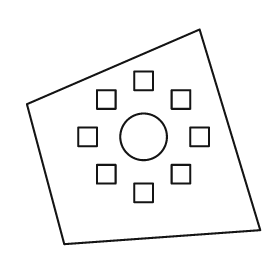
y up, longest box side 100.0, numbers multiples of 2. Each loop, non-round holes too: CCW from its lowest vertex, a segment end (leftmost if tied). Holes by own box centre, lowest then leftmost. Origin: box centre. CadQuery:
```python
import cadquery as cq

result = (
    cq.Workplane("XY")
    .moveTo(-34.0, -46.0)
    .lineTo(50.0, -40.0)
    .lineTo(24.0, 46.0)
    .lineTo(-50.0, 14.0)
    .close()
    .moveTo(-4.0, -28.0)
    .lineTo(4.0, -28.0)
    .lineTo(4.0, -20.0)
    .lineTo(-4.0, -20.0)
    .close()
    .moveTo(-20.0, -20.0)
    .lineTo(-12.0, -20.0)
    .lineTo(-12.0, -12.0)
    .lineTo(-20.0, -12.0)
    .close()
    .moveTo(12.0, -20.0)
    .lineTo(20.0, -20.0)
    .lineTo(20.0, -12.0)
    .lineTo(12.0, -12.0)
    .close()
    .moveTo(-28.0, -4.0)
    .lineTo(-20.0, -4.0)
    .lineTo(-20.0, 4.0)
    .lineTo(-28.0, 4.0)
    .close()
    .moveTo(0.0, 0.0)
    .circle(10.0)
    .moveTo(20.0, -4.0)
    .lineTo(28.0, -4.0)
    .lineTo(28.0, 4.0)
    .lineTo(20.0, 4.0)
    .close()
    .moveTo(-20.0, 12.0)
    .lineTo(-12.0, 12.0)
    .lineTo(-12.0, 20.0)
    .lineTo(-20.0, 20.0)
    .close()
    .moveTo(12.0, 12.0)
    .lineTo(20.0, 12.0)
    .lineTo(20.0, 20.0)
    .lineTo(12.0, 20.0)
    .close()
    .moveTo(-4.0, 20.0)
    .lineTo(4.0, 20.0)
    .lineTo(4.0, 28.0)
    .lineTo(-4.0, 28.0)
    .close()
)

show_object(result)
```